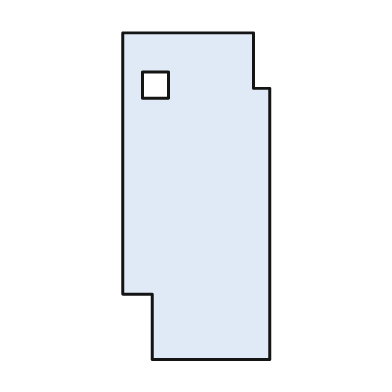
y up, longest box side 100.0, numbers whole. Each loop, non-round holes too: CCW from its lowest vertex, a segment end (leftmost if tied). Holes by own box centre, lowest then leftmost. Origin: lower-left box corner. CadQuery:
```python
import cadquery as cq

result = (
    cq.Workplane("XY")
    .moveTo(9.0, 0.0)
    .lineTo(45.0, 0.0)
    .lineTo(45.0, 83.0)
    .lineTo(40.0, 83.0)
    .lineTo(40.0, 100.0)
    .lineTo(0.0, 100.0)
    .lineTo(0.0, 20.0)
    .lineTo(9.0, 20.0)
    .close()
    .moveTo(6.0, 80.0)
    .lineTo(14.0, 80.0)
    .lineTo(14.0, 88.0)
    .lineTo(6.0, 88.0)
    .close()
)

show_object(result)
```